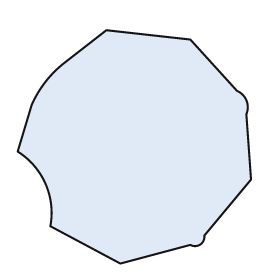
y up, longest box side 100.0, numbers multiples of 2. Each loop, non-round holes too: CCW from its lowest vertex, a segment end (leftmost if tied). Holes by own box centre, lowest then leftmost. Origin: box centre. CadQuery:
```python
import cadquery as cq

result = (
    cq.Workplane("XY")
    .moveTo(-6.0, -50.0)
    .lineTo(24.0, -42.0)
    .threePointArc((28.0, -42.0), (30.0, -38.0))
    .lineTo(50.0, -14.0)
    .lineTo(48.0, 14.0)
    .threePointArc((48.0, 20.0), (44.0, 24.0))
    .lineTo(24.0, 46.0)
    .lineTo(-12.0, 50.0)
    .lineTo(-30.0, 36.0)
    .threePointArc((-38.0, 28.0), (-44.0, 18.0))
    .lineTo(-50.0, -2.0)
    .threePointArc((-38.0, -16.0), (-36.0, -34.0))
    .close()
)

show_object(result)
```